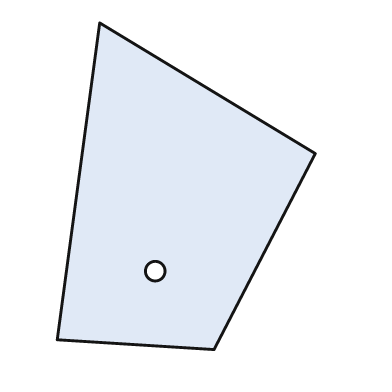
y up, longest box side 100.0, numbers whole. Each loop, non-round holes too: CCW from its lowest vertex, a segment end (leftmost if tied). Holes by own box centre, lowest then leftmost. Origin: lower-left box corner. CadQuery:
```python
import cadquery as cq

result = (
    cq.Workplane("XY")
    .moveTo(48.0, 0.0)
    .lineTo(79.0, 60.0)
    .lineTo(13.0, 100.0)
    .lineTo(0.0, 3.0)
    .close()
    .moveTo(30.0, 24.0)
    .circle(3.0)
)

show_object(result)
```